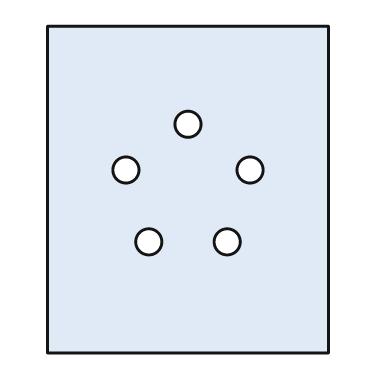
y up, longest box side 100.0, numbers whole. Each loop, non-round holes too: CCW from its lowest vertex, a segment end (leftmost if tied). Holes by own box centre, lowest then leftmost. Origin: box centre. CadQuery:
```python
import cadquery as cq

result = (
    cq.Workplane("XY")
    .moveTo(-43.0, -50.0)
    .lineTo(43.0, -50.0)
    .lineTo(43.0, 50.0)
    .lineTo(-43.0, 50.0)
    .close()
    .moveTo(-12.0, -16.0)
    .circle(4.0)
    .moveTo(12.0, -16.0)
    .circle(4.0)
    .moveTo(-19.0, 6.0)
    .circle(4.0)
    .moveTo(19.0, 6.0)
    .circle(4.0)
    .moveTo(0.0, 20.0)
    .circle(4.0)
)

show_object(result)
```